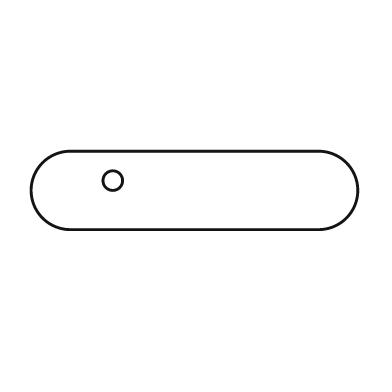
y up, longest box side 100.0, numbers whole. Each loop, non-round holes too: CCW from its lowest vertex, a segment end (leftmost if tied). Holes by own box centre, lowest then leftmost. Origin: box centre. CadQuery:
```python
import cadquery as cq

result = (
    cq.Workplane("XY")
    .moveTo(-38.0, -12.0)
    .lineTo(38.0, -12.0)
    .threePointArc((50.0, 0.0), (38.0, 12.0))
    .lineTo(-38.0, 12.0)
    .threePointArc((-50.0, 0.0), (-38.0, -12.0))
    .close()
    .moveTo(-25.0, 3.0)
    .circle(3.0)
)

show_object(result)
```